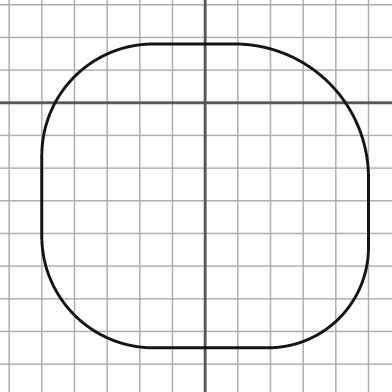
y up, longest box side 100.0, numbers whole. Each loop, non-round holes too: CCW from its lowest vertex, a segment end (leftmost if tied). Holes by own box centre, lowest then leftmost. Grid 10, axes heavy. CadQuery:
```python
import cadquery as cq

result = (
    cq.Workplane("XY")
    .moveTo(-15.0, -75.0)
    .lineTo(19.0, -75.0)
    .threePointArc((41.0, -66.0), (50.0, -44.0))
    .lineTo(50.0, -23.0)
    .threePointArc((38.0, 6.0), (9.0, 18.0))
    .lineTo(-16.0, 18.0)
    .threePointArc((-40.0, 8.0), (-50.0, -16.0))
    .lineTo(-50.0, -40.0)
    .threePointArc((-40.0, -65.0), (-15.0, -75.0))
    .close()
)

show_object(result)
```